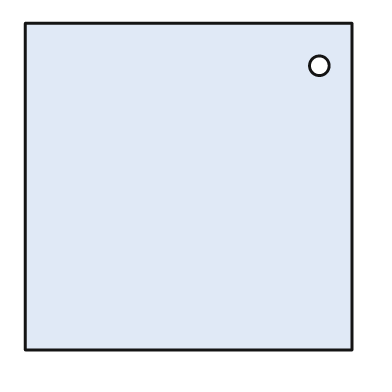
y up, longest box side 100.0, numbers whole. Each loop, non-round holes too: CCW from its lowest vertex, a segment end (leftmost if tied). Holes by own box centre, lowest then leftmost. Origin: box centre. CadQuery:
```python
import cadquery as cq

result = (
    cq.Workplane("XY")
    .moveTo(-50.0, -50.0)
    .lineTo(50.0, -50.0)
    .lineTo(50.0, 50.0)
    .lineTo(-50.0, 50.0)
    .close()
    .moveTo(40.0, 37.0)
    .circle(3.0)
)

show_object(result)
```